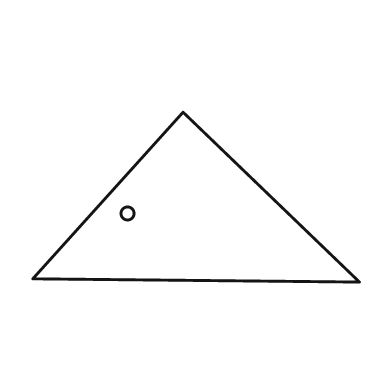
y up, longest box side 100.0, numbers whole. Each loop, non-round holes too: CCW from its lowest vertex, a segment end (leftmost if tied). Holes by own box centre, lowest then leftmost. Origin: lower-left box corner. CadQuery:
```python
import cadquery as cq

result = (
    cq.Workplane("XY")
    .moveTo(100.0, 0.0)
    .lineTo(46.0, 52.0)
    .lineTo(0.0, 1.0)
    .close()
    .moveTo(29.0, 21.0)
    .circle(2.0)
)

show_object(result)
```